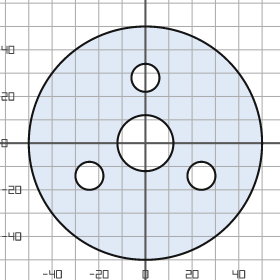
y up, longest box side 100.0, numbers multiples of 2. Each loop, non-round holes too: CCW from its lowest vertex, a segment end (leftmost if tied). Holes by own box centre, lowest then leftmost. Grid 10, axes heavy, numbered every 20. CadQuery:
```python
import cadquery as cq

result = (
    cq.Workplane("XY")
    .moveTo(0.0, 0.0)
    .circle(50.0)
    .moveTo(-24.0, -14.0)
    .circle(6.0)
    .moveTo(24.0, -14.0)
    .circle(6.0)
    .moveTo(0.0, 0.0)
    .circle(12.0)
    .moveTo(0.0, 28.0)
    .circle(6.0)
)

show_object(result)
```